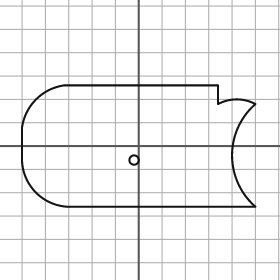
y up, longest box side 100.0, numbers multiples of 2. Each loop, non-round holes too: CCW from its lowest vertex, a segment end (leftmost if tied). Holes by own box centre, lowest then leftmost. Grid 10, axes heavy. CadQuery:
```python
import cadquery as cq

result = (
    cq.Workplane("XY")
    .moveTo(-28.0, -26.0)
    .lineTo(50.0, -26.0)
    .threePointArc((40.0, -4.0), (50.0, 18.0))
    .threePointArc((42.0, 20.0), (34.0, 18.0))
    .lineTo(34.0, 26.0)
    .lineTo(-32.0, 26.0)
    .threePointArc((-44.0, 20.0), (-50.0, 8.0))
    .lineTo(-50.0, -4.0)
    .threePointArc((-44.0, -20.0), (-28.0, -26.0))
    .close()
    .moveTo(-2.0, -6.0)
    .circle(2.0)
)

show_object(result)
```